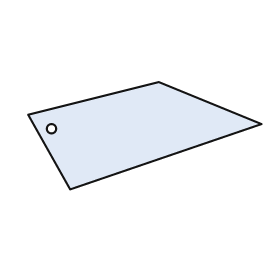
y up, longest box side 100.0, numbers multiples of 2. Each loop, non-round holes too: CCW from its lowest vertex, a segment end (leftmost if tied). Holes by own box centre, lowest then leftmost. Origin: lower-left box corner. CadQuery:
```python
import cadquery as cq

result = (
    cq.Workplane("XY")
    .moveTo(18.0, 0.0)
    .lineTo(100.0, 28.0)
    .lineTo(56.0, 46.0)
    .lineTo(0.0, 32.0)
    .close()
    .moveTo(10.0, 26.0)
    .circle(2.0)
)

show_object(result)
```